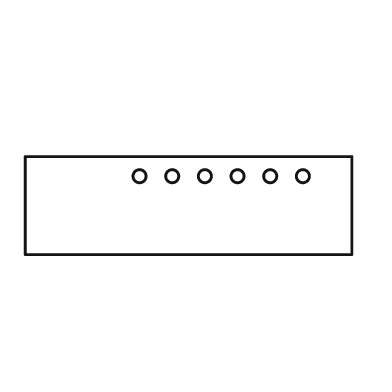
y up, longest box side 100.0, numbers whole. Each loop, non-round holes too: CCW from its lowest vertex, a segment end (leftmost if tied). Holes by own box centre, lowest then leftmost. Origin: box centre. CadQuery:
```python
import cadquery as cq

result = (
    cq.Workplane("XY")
    .moveTo(-50.0, -15.0)
    .lineTo(50.0, -15.0)
    .lineTo(50.0, 15.0)
    .lineTo(-50.0, 15.0)
    .close()
    .moveTo(-15.0, 9.0)
    .circle(2.0)
    .moveTo(-5.0, 9.0)
    .circle(2.0)
    .moveTo(5.0, 9.0)
    .circle(2.0)
    .moveTo(15.0, 9.0)
    .circle(2.0)
    .moveTo(25.0, 9.0)
    .circle(2.0)
    .moveTo(35.0, 9.0)
    .circle(2.0)
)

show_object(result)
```